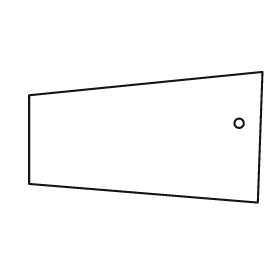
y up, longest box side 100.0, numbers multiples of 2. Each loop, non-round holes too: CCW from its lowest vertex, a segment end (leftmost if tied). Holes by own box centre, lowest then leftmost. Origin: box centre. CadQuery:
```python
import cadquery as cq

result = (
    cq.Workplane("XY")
    .moveTo(48.0, -28.0)
    .lineTo(50.0, 28.0)
    .lineTo(-50.0, 18.0)
    .lineTo(-50.0, -20.0)
    .close()
    .moveTo(40.0, 6.0)
    .circle(2.0)
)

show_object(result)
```